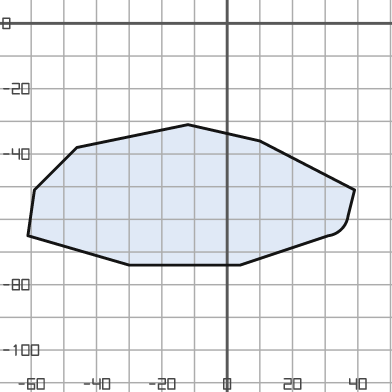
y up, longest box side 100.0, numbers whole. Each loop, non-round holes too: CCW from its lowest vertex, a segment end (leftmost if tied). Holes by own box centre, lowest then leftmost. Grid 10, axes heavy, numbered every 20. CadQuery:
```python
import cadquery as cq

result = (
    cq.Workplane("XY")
    .moveTo(-30.0, -74.0)
    .lineTo(4.0, -74.0)
    .lineTo(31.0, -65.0)
    .threePointArc((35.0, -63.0), (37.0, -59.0))
    .lineTo(39.0, -51.0)
    .lineTo(10.0, -36.0)
    .lineTo(-12.0, -31.0)
    .lineTo(-46.0, -38.0)
    .lineTo(-59.0, -51.0)
    .lineTo(-61.0, -65.0)
    .close()
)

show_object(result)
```